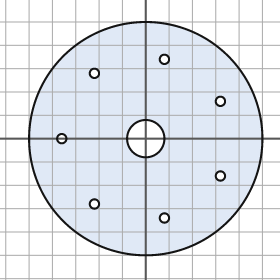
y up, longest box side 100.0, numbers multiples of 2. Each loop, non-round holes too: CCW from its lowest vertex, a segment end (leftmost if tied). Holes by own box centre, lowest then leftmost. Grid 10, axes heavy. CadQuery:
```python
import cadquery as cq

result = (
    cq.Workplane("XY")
    .moveTo(0.0, 0.0)
    .circle(50.0)
    .moveTo(8.0, -34.0)
    .circle(2.0)
    .moveTo(-22.0, -28.0)
    .circle(2.0)
    .moveTo(32.0, -16.0)
    .circle(2.0)
    .moveTo(-36.0, 0.0)
    .circle(2.0)
    .moveTo(0.0, 0.0)
    .circle(8.0)
    .moveTo(32.0, 16.0)
    .circle(2.0)
    .moveTo(-22.0, 28.0)
    .circle(2.0)
    .moveTo(8.0, 34.0)
    .circle(2.0)
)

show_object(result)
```